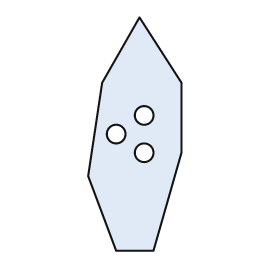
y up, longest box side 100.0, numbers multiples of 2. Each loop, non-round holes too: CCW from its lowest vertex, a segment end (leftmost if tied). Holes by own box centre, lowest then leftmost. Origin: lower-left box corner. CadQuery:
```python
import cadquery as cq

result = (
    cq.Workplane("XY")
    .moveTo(12.0, 0.0)
    .lineTo(28.0, 0.0)
    .lineTo(40.0, 42.0)
    .lineTo(40.0, 72.0)
    .lineTo(22.0, 100.0)
    .lineTo(6.0, 72.0)
    .lineTo(0.0, 32.0)
    .close()
    .moveTo(24.0, 42.0)
    .circle(4.0)
    .moveTo(12.0, 50.0)
    .circle(4.0)
    .moveTo(24.0, 58.0)
    .circle(4.0)
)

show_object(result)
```